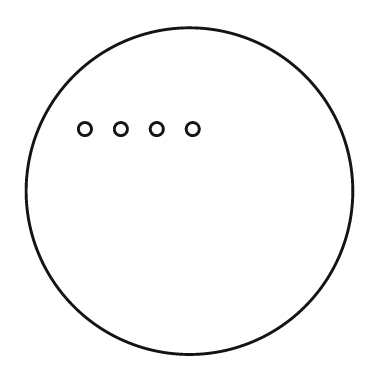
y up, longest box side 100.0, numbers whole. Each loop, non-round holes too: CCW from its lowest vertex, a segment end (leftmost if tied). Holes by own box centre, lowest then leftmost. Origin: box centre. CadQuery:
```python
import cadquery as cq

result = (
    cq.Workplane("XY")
    .moveTo(0.0, 0.0)
    .circle(50.0)
    .moveTo(-32.0, 19.0)
    .circle(2.0)
    .moveTo(-21.0, 19.0)
    .circle(2.0)
    .moveTo(-10.0, 19.0)
    .circle(2.0)
    .moveTo(1.0, 19.0)
    .circle(2.0)
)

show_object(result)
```